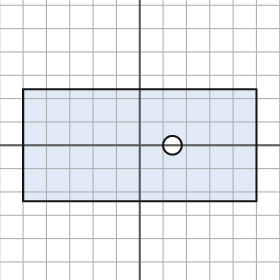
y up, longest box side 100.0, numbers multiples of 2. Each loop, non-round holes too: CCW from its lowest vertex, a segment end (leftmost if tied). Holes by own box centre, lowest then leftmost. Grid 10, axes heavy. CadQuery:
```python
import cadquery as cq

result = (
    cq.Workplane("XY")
    .moveTo(-50.0, -24.0)
    .lineTo(50.0, -24.0)
    .lineTo(50.0, 24.0)
    .lineTo(-50.0, 24.0)
    .close()
    .moveTo(14.0, 0.0)
    .circle(4.0)
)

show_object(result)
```